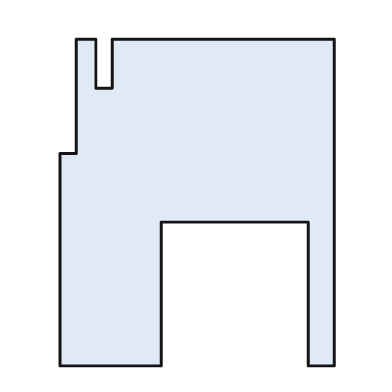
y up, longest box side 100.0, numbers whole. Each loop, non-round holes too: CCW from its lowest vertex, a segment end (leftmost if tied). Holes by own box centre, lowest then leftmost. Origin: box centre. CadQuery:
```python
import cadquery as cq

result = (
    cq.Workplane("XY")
    .moveTo(-42.0, -50.0)
    .lineTo(-11.0, -50.0)
    .lineTo(-11.0, -6.0)
    .lineTo(34.0, -6.0)
    .lineTo(34.0, -50.0)
    .lineTo(42.0, -50.0)
    .lineTo(42.0, 50.0)
    .lineTo(-26.0, 50.0)
    .lineTo(-26.0, 35.0)
    .lineTo(-31.0, 35.0)
    .lineTo(-31.0, 50.0)
    .lineTo(-37.0, 50.0)
    .lineTo(-37.0, 15.0)
    .lineTo(-42.0, 15.0)
    .close()
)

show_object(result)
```